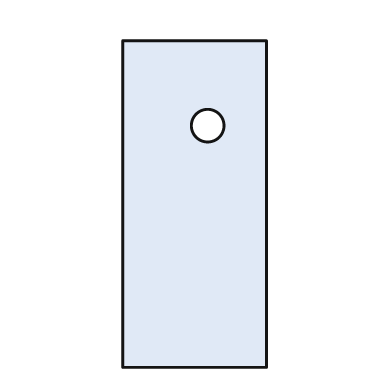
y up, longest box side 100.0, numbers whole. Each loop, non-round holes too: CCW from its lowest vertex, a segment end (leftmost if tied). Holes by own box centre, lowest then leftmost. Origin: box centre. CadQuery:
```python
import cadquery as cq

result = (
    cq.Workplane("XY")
    .moveTo(-22.0, -50.0)
    .lineTo(22.0, -50.0)
    .lineTo(22.0, 50.0)
    .lineTo(-22.0, 50.0)
    .close()
    .moveTo(4.0, 24.0)
    .circle(5.0)
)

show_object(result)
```